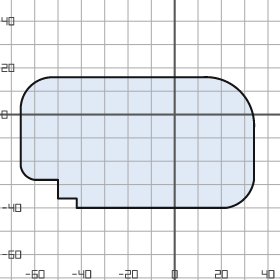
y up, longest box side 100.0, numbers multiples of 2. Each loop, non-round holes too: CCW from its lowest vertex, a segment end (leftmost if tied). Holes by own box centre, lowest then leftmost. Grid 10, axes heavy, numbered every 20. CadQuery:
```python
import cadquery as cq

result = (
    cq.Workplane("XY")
    .moveTo(-42.0, -40.0)
    .lineTo(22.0, -40.0)
    .threePointArc((30.0, -36.0), (34.0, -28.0))
    .lineTo(34.0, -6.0)
    .threePointArc((28.0, 10.0), (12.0, 16.0))
    .lineTo(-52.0, 16.0)
    .threePointArc((-62.0, 12.0), (-66.0, 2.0))
    .lineTo(-66.0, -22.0)
    .threePointArc((-64.0, -26.0), (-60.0, -28.0))
    .lineTo(-50.0, -28.0)
    .lineTo(-50.0, -36.0)
    .lineTo(-42.0, -36.0)
    .close()
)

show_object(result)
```